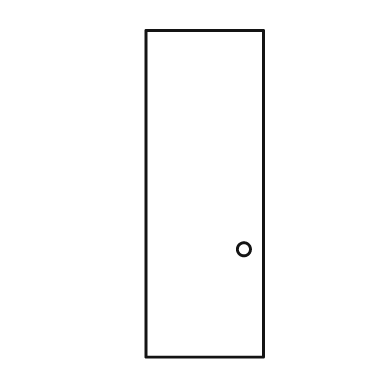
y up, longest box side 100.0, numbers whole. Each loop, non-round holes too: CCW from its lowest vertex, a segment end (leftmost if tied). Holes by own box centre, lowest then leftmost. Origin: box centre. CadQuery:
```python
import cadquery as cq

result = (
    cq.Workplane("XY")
    .moveTo(-18.0, -50.0)
    .lineTo(18.0, -50.0)
    .lineTo(18.0, 50.0)
    .lineTo(-18.0, 50.0)
    .close()
    .moveTo(12.0, -17.0)
    .circle(2.0)
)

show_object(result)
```